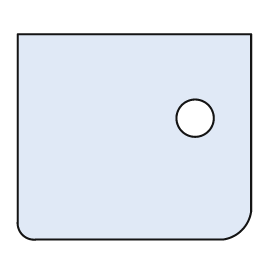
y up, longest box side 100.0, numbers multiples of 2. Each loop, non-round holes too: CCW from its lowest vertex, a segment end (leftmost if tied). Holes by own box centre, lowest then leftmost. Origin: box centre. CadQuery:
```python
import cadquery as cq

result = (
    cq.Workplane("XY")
    .moveTo(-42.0, -44.0)
    .lineTo(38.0, -44.0)
    .threePointArc((46.0, -40.0), (50.0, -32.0))
    .lineTo(50.0, 44.0)
    .lineTo(-50.0, 44.0)
    .lineTo(-50.0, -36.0)
    .threePointArc((-48.0, -42.0), (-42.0, -44.0))
    .close()
    .moveTo(26.0, 8.0)
    .circle(8.0)
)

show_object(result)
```